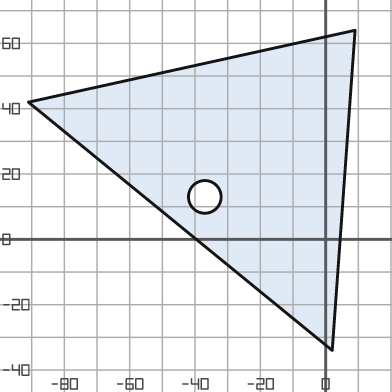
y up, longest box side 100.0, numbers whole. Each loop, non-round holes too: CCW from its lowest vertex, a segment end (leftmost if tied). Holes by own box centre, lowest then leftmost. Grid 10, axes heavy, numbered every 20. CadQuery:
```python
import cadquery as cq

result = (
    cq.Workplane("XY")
    .moveTo(2.0, -34.0)
    .lineTo(9.0, 64.0)
    .lineTo(-91.0, 42.0)
    .close()
    .moveTo(-37.0, 13.0)
    .circle(5.0)
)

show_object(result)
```